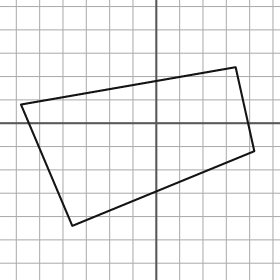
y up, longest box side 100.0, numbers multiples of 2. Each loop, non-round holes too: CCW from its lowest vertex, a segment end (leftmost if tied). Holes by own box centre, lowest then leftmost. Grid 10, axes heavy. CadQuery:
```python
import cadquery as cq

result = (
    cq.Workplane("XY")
    .moveTo(-36.0, -44.0)
    .lineTo(42.0, -12.0)
    .lineTo(34.0, 24.0)
    .lineTo(-58.0, 8.0)
    .close()
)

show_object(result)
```